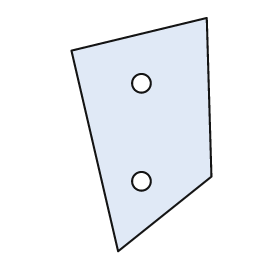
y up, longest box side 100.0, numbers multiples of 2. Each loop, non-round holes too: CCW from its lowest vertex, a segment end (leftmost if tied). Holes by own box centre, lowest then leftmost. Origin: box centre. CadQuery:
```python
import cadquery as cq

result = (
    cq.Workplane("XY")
    .moveTo(-10.0, -50.0)
    .lineTo(30.0, -18.0)
    .lineTo(28.0, 50.0)
    .lineTo(-30.0, 36.0)
    .close()
    .moveTo(0.0, -20.0)
    .circle(4.0)
    .moveTo(0.0, 22.0)
    .circle(4.0)
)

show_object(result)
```